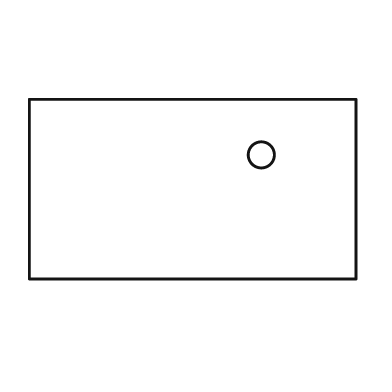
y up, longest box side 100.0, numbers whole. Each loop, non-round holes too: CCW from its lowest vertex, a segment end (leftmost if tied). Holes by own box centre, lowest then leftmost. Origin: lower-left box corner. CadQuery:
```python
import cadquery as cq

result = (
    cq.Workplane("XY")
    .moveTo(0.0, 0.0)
    .lineTo(100.0, 0.0)
    .lineTo(100.0, 55.0)
    .lineTo(0.0, 55.0)
    .close()
    .moveTo(71.0, 38.0)
    .circle(4.0)
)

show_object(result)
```